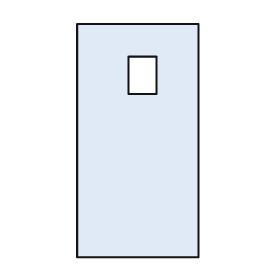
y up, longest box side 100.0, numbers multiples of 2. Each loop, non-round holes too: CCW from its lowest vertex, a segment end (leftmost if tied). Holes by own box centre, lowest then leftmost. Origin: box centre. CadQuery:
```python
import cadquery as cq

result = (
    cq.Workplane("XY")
    .moveTo(-26.0, -50.0)
    .lineTo(26.0, -50.0)
    .lineTo(26.0, 50.0)
    .lineTo(-26.0, 50.0)
    .close()
    .moveTo(-4.0, 20.0)
    .lineTo(8.0, 20.0)
    .lineTo(8.0, 36.0)
    .lineTo(-4.0, 36.0)
    .close()
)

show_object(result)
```